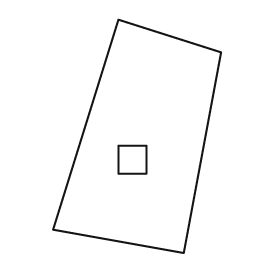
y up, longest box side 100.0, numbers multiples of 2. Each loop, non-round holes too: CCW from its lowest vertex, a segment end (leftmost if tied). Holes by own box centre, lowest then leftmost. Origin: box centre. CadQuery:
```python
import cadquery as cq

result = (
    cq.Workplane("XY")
    .moveTo(20.0, -50.0)
    .lineTo(36.0, 36.0)
    .lineTo(-8.0, 50.0)
    .lineTo(-36.0, -40.0)
    .close()
    .moveTo(-8.0, -16.0)
    .lineTo(4.0, -16.0)
    .lineTo(4.0, -4.0)
    .lineTo(-8.0, -4.0)
    .close()
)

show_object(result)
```